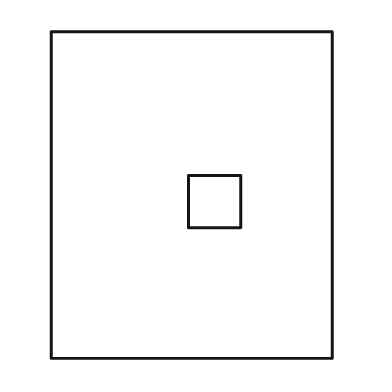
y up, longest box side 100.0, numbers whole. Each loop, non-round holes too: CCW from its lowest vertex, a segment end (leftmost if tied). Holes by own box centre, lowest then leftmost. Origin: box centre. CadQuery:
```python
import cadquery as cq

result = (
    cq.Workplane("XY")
    .moveTo(-43.0, -50.0)
    .lineTo(43.0, -50.0)
    .lineTo(43.0, 50.0)
    .lineTo(-43.0, 50.0)
    .close()
    .moveTo(-1.0, -10.0)
    .lineTo(15.0, -10.0)
    .lineTo(15.0, 6.0)
    .lineTo(-1.0, 6.0)
    .close()
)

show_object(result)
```